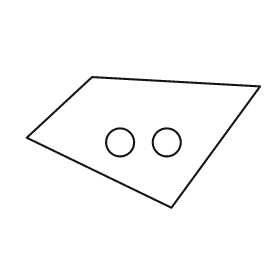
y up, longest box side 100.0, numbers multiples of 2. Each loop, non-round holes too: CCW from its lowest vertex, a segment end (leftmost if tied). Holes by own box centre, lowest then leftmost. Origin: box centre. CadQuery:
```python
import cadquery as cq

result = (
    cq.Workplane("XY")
    .moveTo(12.0, -28.0)
    .lineTo(50.0, 24.0)
    .lineTo(-22.0, 28.0)
    .lineTo(-50.0, 2.0)
    .close()
    .moveTo(-10.0, 0.0)
    .circle(6.0)
    .moveTo(10.0, 0.0)
    .circle(6.0)
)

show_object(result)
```